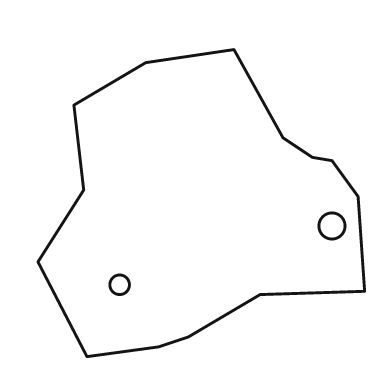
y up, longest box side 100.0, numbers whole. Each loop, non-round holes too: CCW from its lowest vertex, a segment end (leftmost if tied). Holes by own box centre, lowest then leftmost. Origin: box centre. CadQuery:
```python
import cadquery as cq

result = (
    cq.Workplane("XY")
    .moveTo(-35.0, -47.0)
    .lineTo(-13.0, -44.0)
    .lineTo(-4.0, -41.0)
    .lineTo(18.0, -28.0)
    .lineTo(50.0, -27.0)
    .lineTo(48.0, 2.0)
    .lineTo(40.0, 13.0)
    .lineTo(34.0, 14.0)
    .lineTo(25.0, 20.0)
    .lineTo(10.0, 47.0)
    .lineTo(-17.0, 43.0)
    .lineTo(-39.0, 30.0)
    .lineTo(-36.0, 4.0)
    .lineTo(-50.0, -18.0)
    .close()
    .moveTo(-25.0, -25.0)
    .circle(3.0)
    .moveTo(40.0, -7.0)
    .circle(4.0)
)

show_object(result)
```